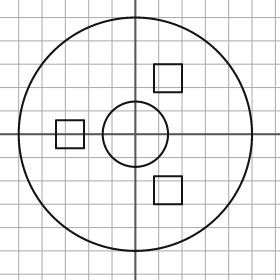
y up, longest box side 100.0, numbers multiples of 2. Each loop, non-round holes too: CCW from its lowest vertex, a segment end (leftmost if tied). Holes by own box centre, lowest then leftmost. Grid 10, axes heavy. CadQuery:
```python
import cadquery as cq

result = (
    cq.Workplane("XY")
    .moveTo(0.0, 0.0)
    .circle(50.0)
    .moveTo(8.0, -30.0)
    .lineTo(20.0, -30.0)
    .lineTo(20.0, -18.0)
    .lineTo(8.0, -18.0)
    .close()
    .moveTo(-34.0, -6.0)
    .lineTo(-22.0, -6.0)
    .lineTo(-22.0, 6.0)
    .lineTo(-34.0, 6.0)
    .close()
    .moveTo(0.0, 0.0)
    .circle(14.0)
    .moveTo(8.0, 18.0)
    .lineTo(20.0, 18.0)
    .lineTo(20.0, 30.0)
    .lineTo(8.0, 30.0)
    .close()
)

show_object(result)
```